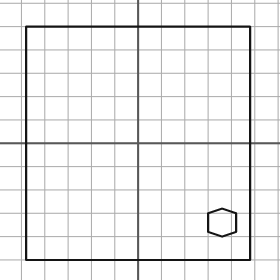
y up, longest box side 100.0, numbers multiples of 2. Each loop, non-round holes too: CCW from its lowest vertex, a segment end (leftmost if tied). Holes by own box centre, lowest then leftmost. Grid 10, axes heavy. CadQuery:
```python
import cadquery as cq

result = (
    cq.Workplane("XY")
    .moveTo(-48.0, -50.0)
    .lineTo(48.0, -50.0)
    .lineTo(48.0, 50.0)
    .lineTo(-48.0, 50.0)
    .close()
    .moveTo(36.0, -40.0)
    .lineTo(42.0, -38.0)
    .lineTo(42.0, -30.0)
    .lineTo(36.0, -28.0)
    .lineTo(30.0, -30.0)
    .lineTo(30.0, -38.0)
    .close()
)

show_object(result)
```